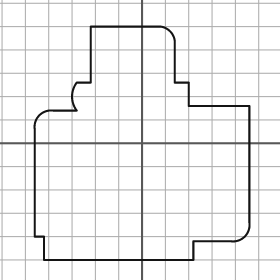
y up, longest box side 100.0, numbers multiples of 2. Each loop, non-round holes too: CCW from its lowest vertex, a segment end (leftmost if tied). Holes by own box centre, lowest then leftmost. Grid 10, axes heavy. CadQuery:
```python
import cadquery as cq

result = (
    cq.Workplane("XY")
    .moveTo(-42.0, -50.0)
    .lineTo(22.0, -50.0)
    .lineTo(22.0, -42.0)
    .lineTo(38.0, -42.0)
    .threePointArc((44.0, -40.0), (46.0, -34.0))
    .lineTo(46.0, 16.0)
    .lineTo(20.0, 16.0)
    .lineTo(20.0, 26.0)
    .lineTo(14.0, 26.0)
    .lineTo(14.0, 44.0)
    .threePointArc((12.0, 48.0), (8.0, 50.0))
    .lineTo(-22.0, 50.0)
    .lineTo(-22.0, 26.0)
    .lineTo(-28.0, 26.0)
    .threePointArc((-30.0, 20.0), (-28.0, 14.0))
    .lineTo(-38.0, 14.0)
    .threePointArc((-44.0, 12.0), (-46.0, 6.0))
    .lineTo(-46.0, -40.0)
    .lineTo(-42.0, -40.0)
    .close()
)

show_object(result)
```